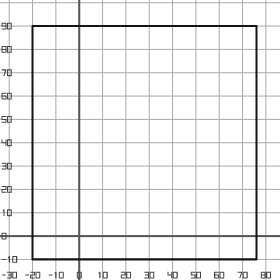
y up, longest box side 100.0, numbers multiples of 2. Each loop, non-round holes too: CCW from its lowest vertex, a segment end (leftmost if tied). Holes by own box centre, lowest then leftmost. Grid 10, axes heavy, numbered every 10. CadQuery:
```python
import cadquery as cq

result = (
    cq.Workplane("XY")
    .moveTo(-20.0, -10.0)
    .lineTo(76.0, -10.0)
    .lineTo(76.0, 90.0)
    .lineTo(-20.0, 90.0)
    .close()
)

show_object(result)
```